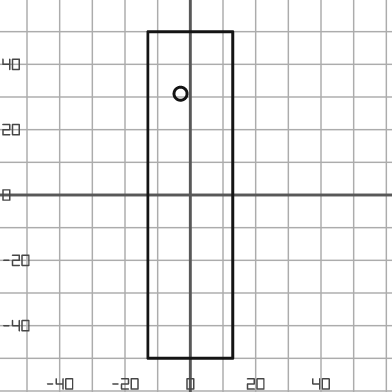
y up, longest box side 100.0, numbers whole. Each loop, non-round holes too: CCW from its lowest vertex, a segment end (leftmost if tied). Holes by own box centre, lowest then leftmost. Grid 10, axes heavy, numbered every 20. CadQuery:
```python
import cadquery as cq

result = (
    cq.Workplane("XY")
    .moveTo(-13.0, -50.0)
    .lineTo(13.0, -50.0)
    .lineTo(13.0, 50.0)
    .lineTo(-13.0, 50.0)
    .close()
    .moveTo(-3.0, 31.0)
    .circle(2.0)
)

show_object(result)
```